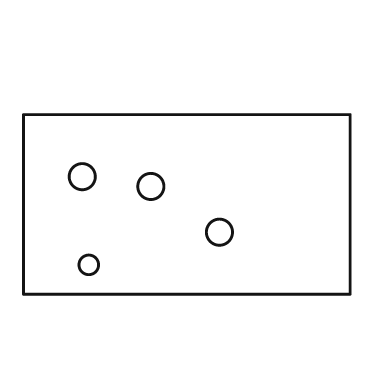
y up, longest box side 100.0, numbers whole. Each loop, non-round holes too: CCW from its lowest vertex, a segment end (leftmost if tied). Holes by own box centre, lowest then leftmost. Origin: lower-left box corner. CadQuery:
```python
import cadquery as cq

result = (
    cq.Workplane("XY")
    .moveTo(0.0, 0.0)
    .lineTo(100.0, 0.0)
    .lineTo(100.0, 55.0)
    .lineTo(0.0, 55.0)
    .close()
    .moveTo(20.0, 9.0)
    .circle(3.0)
    .moveTo(60.0, 19.0)
    .circle(4.0)
    .moveTo(39.0, 33.0)
    .circle(4.0)
    .moveTo(18.0, 36.0)
    .circle(4.0)
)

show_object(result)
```